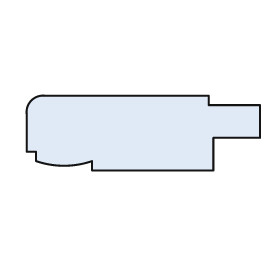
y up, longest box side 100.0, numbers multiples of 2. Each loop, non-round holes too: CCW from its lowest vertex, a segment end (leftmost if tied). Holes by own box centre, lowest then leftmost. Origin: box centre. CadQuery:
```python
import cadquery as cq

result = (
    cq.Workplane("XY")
    .moveTo(-22.0, -16.0)
    .lineTo(30.0, -16.0)
    .lineTo(30.0, -2.0)
    .lineTo(50.0, -2.0)
    .lineTo(50.0, 12.0)
    .lineTo(28.0, 12.0)
    .lineTo(28.0, 16.0)
    .lineTo(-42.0, 16.0)
    .threePointArc((-48.0, 14.0), (-50.0, 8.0))
    .lineTo(-50.0, -8.0)
    .lineTo(-46.0, -8.0)
    .lineTo(-46.0, -12.0)
    .threePointArc((-34.0, -14.0), (-22.0, -12.0))
    .close()
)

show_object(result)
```